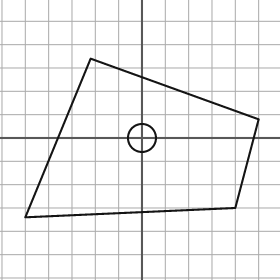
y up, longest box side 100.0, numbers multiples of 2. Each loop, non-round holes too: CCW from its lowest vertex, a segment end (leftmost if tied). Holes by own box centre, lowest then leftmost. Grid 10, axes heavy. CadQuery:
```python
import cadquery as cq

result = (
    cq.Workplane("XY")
    .moveTo(-50.0, -34.0)
    .lineTo(40.0, -30.0)
    .lineTo(50.0, 8.0)
    .lineTo(-22.0, 34.0)
    .close()
    .moveTo(0.0, 0.0)
    .circle(6.0)
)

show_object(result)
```